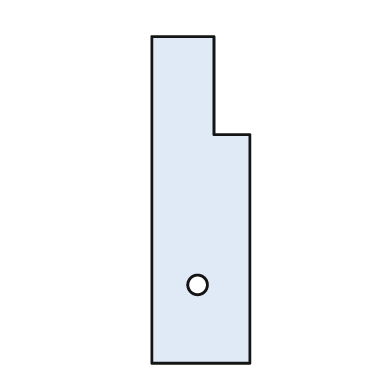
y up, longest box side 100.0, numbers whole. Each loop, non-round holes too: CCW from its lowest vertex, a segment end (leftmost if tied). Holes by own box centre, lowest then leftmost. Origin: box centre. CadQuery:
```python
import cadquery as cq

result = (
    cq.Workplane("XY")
    .moveTo(-15.0, -50.0)
    .lineTo(15.0, -50.0)
    .lineTo(15.0, 20.0)
    .lineTo(4.0, 20.0)
    .lineTo(4.0, 50.0)
    .lineTo(-15.0, 50.0)
    .close()
    .moveTo(-1.0, -26.0)
    .circle(3.0)
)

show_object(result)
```